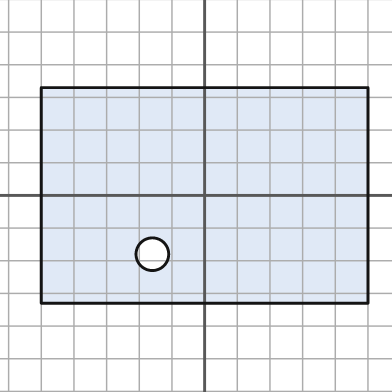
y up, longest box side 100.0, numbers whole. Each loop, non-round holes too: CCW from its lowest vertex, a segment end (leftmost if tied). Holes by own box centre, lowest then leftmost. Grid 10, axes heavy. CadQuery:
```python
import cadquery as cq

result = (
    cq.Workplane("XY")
    .moveTo(-50.0, -33.0)
    .lineTo(50.0, -33.0)
    .lineTo(50.0, 33.0)
    .lineTo(-50.0, 33.0)
    .close()
    .moveTo(-16.0, -18.0)
    .circle(5.0)
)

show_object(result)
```